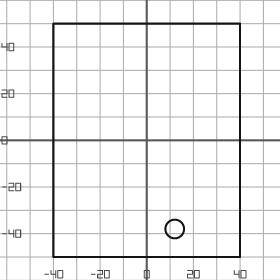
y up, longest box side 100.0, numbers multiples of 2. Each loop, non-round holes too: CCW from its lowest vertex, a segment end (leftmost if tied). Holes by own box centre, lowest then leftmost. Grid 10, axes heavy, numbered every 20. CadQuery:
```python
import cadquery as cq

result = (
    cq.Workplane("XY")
    .moveTo(-40.0, -50.0)
    .lineTo(40.0, -50.0)
    .lineTo(40.0, 50.0)
    .lineTo(-40.0, 50.0)
    .close()
    .moveTo(12.0, -38.0)
    .circle(4.0)
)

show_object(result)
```